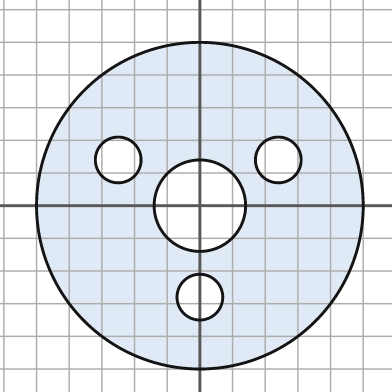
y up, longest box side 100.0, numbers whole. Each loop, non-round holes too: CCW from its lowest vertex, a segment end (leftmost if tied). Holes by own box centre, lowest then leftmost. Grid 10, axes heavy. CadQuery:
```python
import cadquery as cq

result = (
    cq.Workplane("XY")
    .moveTo(0.0, 0.0)
    .circle(50.0)
    .moveTo(0.0, -28.0)
    .circle(7.0)
    .moveTo(0.0, 0.0)
    .circle(14.0)
    .moveTo(-25.0, 14.0)
    .circle(7.0)
    .moveTo(24.0, 14.0)
    .circle(7.0)
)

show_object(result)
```